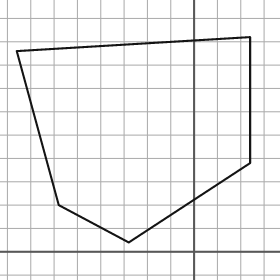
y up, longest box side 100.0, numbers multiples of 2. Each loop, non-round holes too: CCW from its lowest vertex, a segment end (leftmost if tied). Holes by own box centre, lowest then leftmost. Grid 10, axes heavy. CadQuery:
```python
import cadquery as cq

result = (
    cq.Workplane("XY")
    .moveTo(-28.0, 4.0)
    .lineTo(24.0, 38.0)
    .lineTo(24.0, 92.0)
    .lineTo(-76.0, 86.0)
    .lineTo(-58.0, 20.0)
    .close()
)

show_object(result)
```